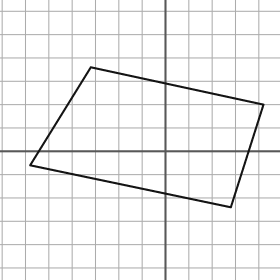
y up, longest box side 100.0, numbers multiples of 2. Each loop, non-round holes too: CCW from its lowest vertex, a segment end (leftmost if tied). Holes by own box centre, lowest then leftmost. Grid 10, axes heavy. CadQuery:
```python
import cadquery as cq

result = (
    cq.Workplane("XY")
    .moveTo(28.0, -24.0)
    .lineTo(42.0, 20.0)
    .lineTo(-32.0, 36.0)
    .lineTo(-58.0, -6.0)
    .close()
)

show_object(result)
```